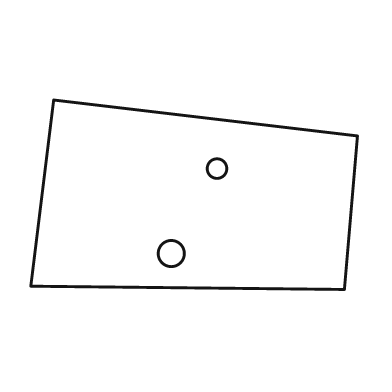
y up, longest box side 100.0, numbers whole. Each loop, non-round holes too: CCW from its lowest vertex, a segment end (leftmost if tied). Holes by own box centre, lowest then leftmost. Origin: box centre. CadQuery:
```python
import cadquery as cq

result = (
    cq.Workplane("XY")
    .moveTo(46.0, -29.0)
    .lineTo(50.0, 18.0)
    .lineTo(-43.0, 29.0)
    .lineTo(-50.0, -28.0)
    .close()
    .moveTo(-7.0, -18.0)
    .circle(4.0)
    .moveTo(7.0, 8.0)
    .circle(3.0)
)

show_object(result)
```